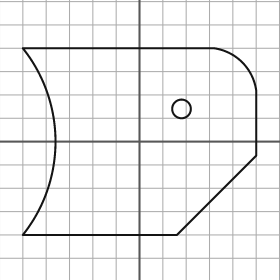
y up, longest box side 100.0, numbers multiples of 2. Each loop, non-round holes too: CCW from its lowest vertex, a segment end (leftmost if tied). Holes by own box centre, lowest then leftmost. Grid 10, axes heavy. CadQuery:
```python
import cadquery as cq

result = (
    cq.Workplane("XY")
    .moveTo(-50.0, -40.0)
    .lineTo(16.0, -40.0)
    .lineTo(50.0, -6.0)
    .lineTo(50.0, 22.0)
    .threePointArc((44.0, 34.0), (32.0, 40.0))
    .lineTo(-50.0, 40.0)
    .threePointArc((-36.0, 0.0), (-50.0, -40.0))
    .close()
    .moveTo(18.0, 14.0)
    .circle(4.0)
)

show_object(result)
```